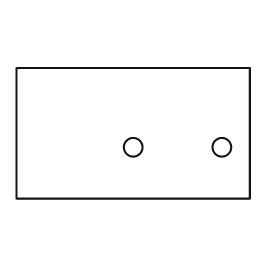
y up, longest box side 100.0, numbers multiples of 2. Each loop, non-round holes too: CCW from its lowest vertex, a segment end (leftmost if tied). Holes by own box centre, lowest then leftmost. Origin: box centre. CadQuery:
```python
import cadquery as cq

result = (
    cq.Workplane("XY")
    .moveTo(-50.0, -28.0)
    .lineTo(50.0, -28.0)
    .lineTo(50.0, 28.0)
    .lineTo(-50.0, 28.0)
    .close()
    .moveTo(0.0, -6.0)
    .circle(4.0)
    .moveTo(38.0, -6.0)
    .circle(4.0)
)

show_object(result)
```